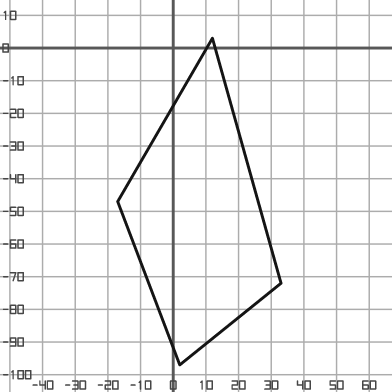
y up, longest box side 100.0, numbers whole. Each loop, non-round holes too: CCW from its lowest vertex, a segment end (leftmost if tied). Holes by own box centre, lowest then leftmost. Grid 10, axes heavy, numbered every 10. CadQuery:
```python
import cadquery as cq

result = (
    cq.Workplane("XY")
    .moveTo(2.0, -97.0)
    .lineTo(33.0, -72.0)
    .lineTo(12.0, 3.0)
    .lineTo(-17.0, -47.0)
    .close()
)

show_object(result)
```